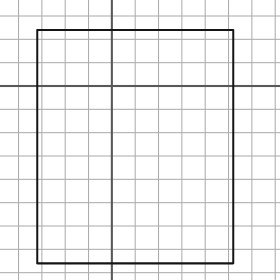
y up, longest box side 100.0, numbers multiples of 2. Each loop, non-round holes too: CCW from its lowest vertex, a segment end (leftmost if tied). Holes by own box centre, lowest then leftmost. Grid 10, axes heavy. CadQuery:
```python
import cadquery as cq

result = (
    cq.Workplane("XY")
    .moveTo(-32.0, -76.0)
    .lineTo(52.0, -76.0)
    .lineTo(52.0, 24.0)
    .lineTo(-32.0, 24.0)
    .close()
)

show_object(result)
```